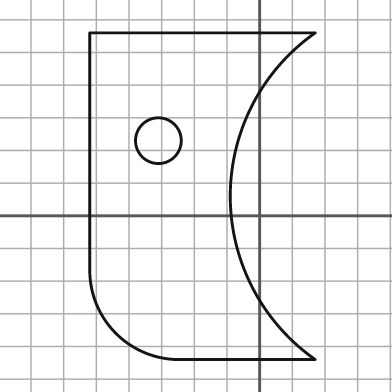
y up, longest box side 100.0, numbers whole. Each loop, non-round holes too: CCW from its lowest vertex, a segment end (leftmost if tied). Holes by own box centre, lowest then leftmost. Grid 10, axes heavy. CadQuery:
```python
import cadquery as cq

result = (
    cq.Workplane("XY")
    .moveTo(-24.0, -44.0)
    .lineTo(17.0, -44.0)
    .threePointArc((-9.0, 6.0), (17.0, 56.0))
    .lineTo(-52.0, 56.0)
    .lineTo(-52.0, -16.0)
    .threePointArc((-44.0, -36.0), (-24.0, -44.0))
    .close()
    .moveTo(-31.0, 23.0)
    .circle(7.0)
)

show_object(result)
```